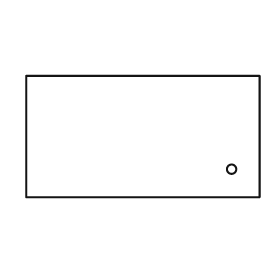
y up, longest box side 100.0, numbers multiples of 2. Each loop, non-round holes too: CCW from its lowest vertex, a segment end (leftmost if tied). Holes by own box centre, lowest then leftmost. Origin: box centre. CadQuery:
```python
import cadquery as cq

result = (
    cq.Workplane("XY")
    .moveTo(-50.0, -26.0)
    .lineTo(50.0, -26.0)
    .lineTo(50.0, 26.0)
    .lineTo(-50.0, 26.0)
    .close()
    .moveTo(38.0, -14.0)
    .circle(2.0)
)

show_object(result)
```